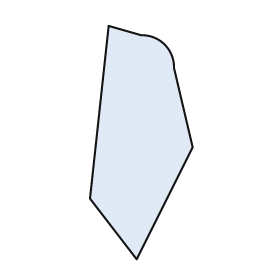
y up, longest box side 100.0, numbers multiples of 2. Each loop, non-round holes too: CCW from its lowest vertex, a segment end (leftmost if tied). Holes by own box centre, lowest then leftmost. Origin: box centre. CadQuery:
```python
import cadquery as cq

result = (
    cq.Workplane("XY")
    .moveTo(-2.0, -50.0)
    .lineTo(22.0, -2.0)
    .lineTo(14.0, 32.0)
    .threePointArc((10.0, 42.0), (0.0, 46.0))
    .lineTo(-14.0, 50.0)
    .lineTo(-22.0, -24.0)
    .close()
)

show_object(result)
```